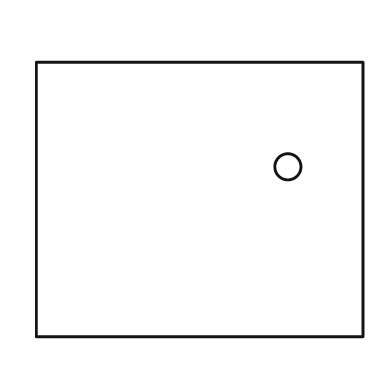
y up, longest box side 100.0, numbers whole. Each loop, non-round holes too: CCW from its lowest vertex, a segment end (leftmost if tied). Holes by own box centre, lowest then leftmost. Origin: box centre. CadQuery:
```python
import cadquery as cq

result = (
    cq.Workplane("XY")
    .moveTo(-50.0, -42.0)
    .lineTo(50.0, -42.0)
    .lineTo(50.0, 42.0)
    .lineTo(-50.0, 42.0)
    .close()
    .moveTo(27.0, 10.0)
    .circle(4.0)
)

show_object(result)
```